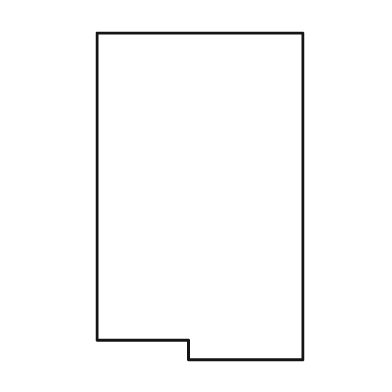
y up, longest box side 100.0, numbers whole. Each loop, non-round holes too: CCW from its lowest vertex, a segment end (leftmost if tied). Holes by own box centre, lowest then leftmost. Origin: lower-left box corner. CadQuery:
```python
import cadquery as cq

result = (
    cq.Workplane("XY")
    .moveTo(28.0, 0.0)
    .lineTo(63.0, 0.0)
    .lineTo(63.0, 100.0)
    .lineTo(0.0, 100.0)
    .lineTo(0.0, 6.0)
    .lineTo(28.0, 6.0)
    .close()
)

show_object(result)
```